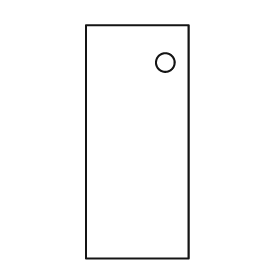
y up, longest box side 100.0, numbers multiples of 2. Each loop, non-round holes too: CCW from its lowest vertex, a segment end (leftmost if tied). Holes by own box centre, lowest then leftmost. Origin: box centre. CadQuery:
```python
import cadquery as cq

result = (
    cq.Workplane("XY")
    .moveTo(-22.0, -50.0)
    .lineTo(22.0, -50.0)
    .lineTo(22.0, 50.0)
    .lineTo(-22.0, 50.0)
    .close()
    .moveTo(12.0, 34.0)
    .circle(4.0)
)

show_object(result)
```